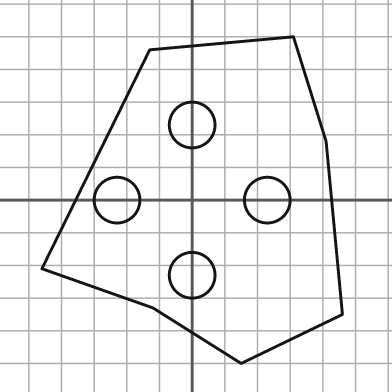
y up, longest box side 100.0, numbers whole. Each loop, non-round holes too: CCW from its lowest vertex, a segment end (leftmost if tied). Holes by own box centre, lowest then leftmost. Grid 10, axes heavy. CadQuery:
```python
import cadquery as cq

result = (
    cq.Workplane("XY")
    .moveTo(15.0, -50.0)
    .lineTo(46.0, -35.0)
    .lineTo(41.0, 18.0)
    .lineTo(31.0, 50.0)
    .lineTo(-13.0, 46.0)
    .lineTo(-46.0, -21.0)
    .lineTo(-12.0, -33.0)
    .close()
    .moveTo(0.0, -23.0)
    .circle(7.0)
    .moveTo(-23.0, 0.0)
    .circle(7.0)
    .moveTo(23.0, 0.0)
    .circle(7.0)
    .moveTo(0.0, 23.0)
    .circle(7.0)
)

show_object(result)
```